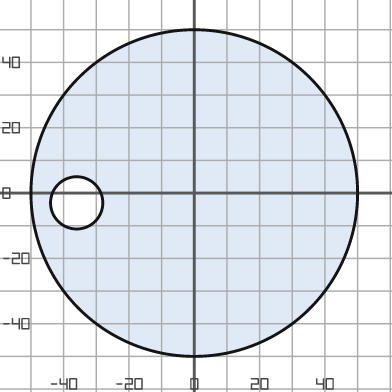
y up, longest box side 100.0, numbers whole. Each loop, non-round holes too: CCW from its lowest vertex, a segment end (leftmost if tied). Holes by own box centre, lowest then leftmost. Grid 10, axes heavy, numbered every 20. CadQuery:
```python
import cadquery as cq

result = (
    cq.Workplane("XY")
    .moveTo(0.0, 0.0)
    .circle(50.0)
    .moveTo(-36.0, -3.0)
    .circle(8.0)
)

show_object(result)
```